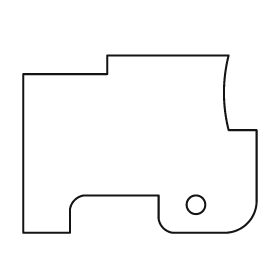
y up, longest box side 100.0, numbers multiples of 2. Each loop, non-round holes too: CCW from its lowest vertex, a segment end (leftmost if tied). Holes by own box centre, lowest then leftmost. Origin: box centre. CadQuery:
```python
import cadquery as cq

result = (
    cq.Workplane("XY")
    .moveTo(-50.0, -38.0)
    .lineTo(-30.0, -38.0)
    .lineTo(-30.0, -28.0)
    .threePointArc((-28.0, -24.0), (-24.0, -22.0))
    .lineTo(8.0, -22.0)
    .lineTo(8.0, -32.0)
    .threePointArc((10.0, -36.0), (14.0, -38.0))
    .lineTo(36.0, -38.0)
    .threePointArc((46.0, -34.0), (50.0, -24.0))
    .lineTo(50.0, 6.0)
    .lineTo(38.0, 6.0)
    .threePointArc((36.0, 22.0), (38.0, 38.0))
    .lineTo(-14.0, 38.0)
    .lineTo(-14.0, 30.0)
    .lineTo(-50.0, 30.0)
    .close()
    .moveTo(24.0, -26.0)
    .circle(4.0)
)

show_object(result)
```